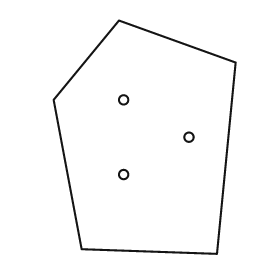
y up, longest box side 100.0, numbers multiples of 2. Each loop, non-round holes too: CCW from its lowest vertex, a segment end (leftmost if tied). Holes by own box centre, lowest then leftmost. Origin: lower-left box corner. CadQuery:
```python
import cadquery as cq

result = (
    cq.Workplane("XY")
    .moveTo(70.0, 0.0)
    .lineTo(78.0, 82.0)
    .lineTo(28.0, 100.0)
    .lineTo(0.0, 66.0)
    .lineTo(12.0, 2.0)
    .close()
    .moveTo(30.0, 34.0)
    .circle(2.0)
    .moveTo(58.0, 50.0)
    .circle(2.0)
    .moveTo(30.0, 66.0)
    .circle(2.0)
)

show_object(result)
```